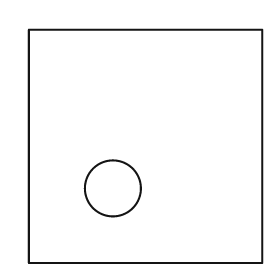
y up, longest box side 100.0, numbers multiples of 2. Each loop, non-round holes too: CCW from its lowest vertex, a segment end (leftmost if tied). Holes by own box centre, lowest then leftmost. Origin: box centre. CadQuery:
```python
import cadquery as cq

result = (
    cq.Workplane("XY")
    .moveTo(-50.0, -50.0)
    .lineTo(50.0, -50.0)
    .lineTo(50.0, 50.0)
    .lineTo(-50.0, 50.0)
    .close()
    .moveTo(-14.0, -18.0)
    .circle(12.0)
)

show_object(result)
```